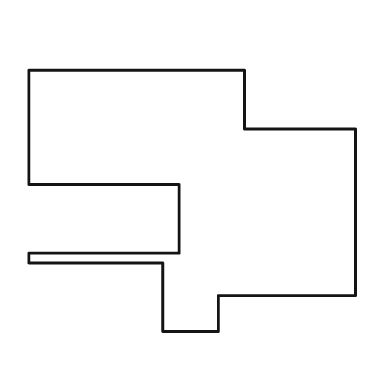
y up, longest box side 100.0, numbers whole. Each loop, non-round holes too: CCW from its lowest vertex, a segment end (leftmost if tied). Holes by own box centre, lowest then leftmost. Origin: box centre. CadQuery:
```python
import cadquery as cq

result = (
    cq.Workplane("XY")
    .moveTo(-9.0, -40.0)
    .lineTo(8.0, -40.0)
    .lineTo(8.0, -29.0)
    .lineTo(50.0, -29.0)
    .lineTo(50.0, 22.0)
    .lineTo(16.0, 22.0)
    .lineTo(16.0, 40.0)
    .lineTo(-50.0, 40.0)
    .lineTo(-50.0, 5.0)
    .lineTo(-4.0, 5.0)
    .lineTo(-4.0, -16.0)
    .lineTo(-50.0, -16.0)
    .lineTo(-50.0, -19.0)
    .lineTo(-9.0, -19.0)
    .close()
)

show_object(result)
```